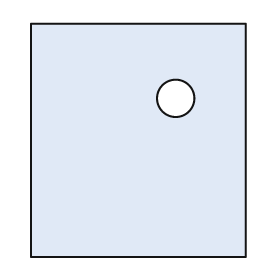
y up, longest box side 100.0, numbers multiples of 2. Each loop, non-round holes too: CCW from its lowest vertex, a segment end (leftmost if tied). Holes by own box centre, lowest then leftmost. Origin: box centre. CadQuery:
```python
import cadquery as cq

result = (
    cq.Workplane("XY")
    .moveTo(-46.0, -50.0)
    .lineTo(46.0, -50.0)
    .lineTo(46.0, 50.0)
    .lineTo(-46.0, 50.0)
    .close()
    .moveTo(16.0, 18.0)
    .circle(8.0)
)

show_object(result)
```